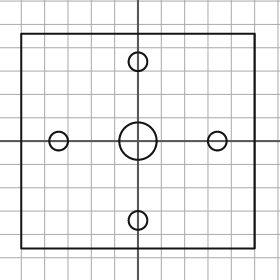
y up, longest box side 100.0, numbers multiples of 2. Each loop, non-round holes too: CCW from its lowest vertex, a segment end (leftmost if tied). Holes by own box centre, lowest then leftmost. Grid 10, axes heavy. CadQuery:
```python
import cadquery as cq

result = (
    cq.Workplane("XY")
    .moveTo(-50.0, -46.0)
    .lineTo(50.0, -46.0)
    .lineTo(50.0, 46.0)
    .lineTo(-50.0, 46.0)
    .close()
    .moveTo(0.0, -34.0)
    .circle(4.0)
    .moveTo(-34.0, 0.0)
    .circle(4.0)
    .moveTo(0.0, 0.0)
    .circle(8.0)
    .moveTo(34.0, 0.0)
    .circle(4.0)
    .moveTo(0.0, 34.0)
    .circle(4.0)
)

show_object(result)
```